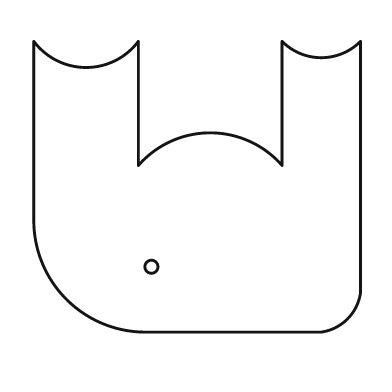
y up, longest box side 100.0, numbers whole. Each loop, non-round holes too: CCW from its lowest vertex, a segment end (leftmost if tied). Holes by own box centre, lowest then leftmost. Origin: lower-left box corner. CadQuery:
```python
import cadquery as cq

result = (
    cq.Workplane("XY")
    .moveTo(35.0, 0.0)
    .lineTo(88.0, 0.0)
    .threePointArc((96.0, 4.0), (100.0, 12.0))
    .lineTo(100.0, 89.0)
    .threePointArc((88.0, 84.0), (76.0, 89.0))
    .lineTo(76.0, 51.0)
    .threePointArc((54.0, 61.0), (32.0, 51.0))
    .lineTo(32.0, 89.0)
    .threePointArc((16.0, 81.0), (0.0, 89.0))
    .lineTo(0.0, 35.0)
    .threePointArc((10.0, 10.0), (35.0, 0.0))
    .close()
    .moveTo(36.0, 20.0)
    .circle(2.0)
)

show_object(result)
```